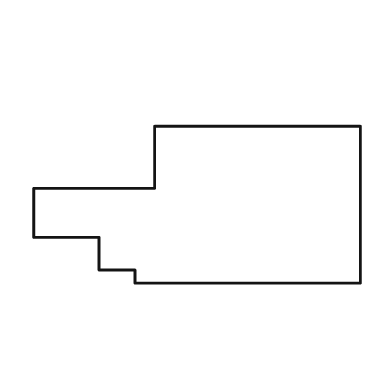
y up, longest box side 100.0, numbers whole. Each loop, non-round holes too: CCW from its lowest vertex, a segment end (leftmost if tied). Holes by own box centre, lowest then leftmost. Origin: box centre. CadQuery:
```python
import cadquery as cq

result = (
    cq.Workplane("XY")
    .moveTo(-19.0, -24.0)
    .lineTo(50.0, -24.0)
    .lineTo(50.0, 24.0)
    .lineTo(-13.0, 24.0)
    .lineTo(-13.0, 5.0)
    .lineTo(-50.0, 5.0)
    .lineTo(-50.0, -10.0)
    .lineTo(-30.0, -10.0)
    .lineTo(-30.0, -20.0)
    .lineTo(-19.0, -20.0)
    .close()
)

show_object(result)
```